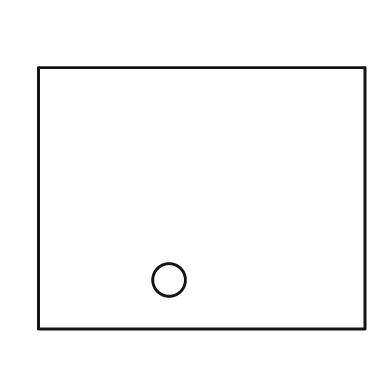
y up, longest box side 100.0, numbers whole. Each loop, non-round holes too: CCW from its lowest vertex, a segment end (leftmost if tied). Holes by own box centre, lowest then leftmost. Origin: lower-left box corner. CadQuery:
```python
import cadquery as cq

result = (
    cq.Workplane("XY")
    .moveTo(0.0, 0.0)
    .lineTo(100.0, 0.0)
    .lineTo(100.0, 80.0)
    .lineTo(0.0, 80.0)
    .close()
    .moveTo(40.0, 15.0)
    .circle(5.0)
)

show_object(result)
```